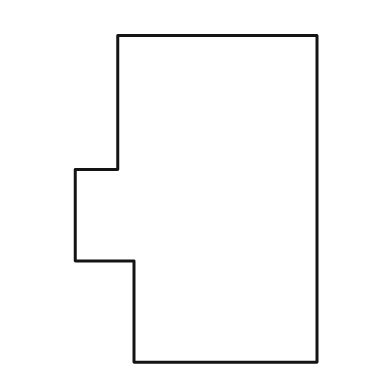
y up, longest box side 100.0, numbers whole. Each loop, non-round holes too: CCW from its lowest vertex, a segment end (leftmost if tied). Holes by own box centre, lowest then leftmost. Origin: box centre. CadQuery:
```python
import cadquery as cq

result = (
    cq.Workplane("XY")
    .moveTo(-19.0, -50.0)
    .lineTo(37.0, -50.0)
    .lineTo(37.0, 50.0)
    .lineTo(-24.0, 50.0)
    .lineTo(-24.0, 9.0)
    .lineTo(-37.0, 9.0)
    .lineTo(-37.0, -19.0)
    .lineTo(-19.0, -19.0)
    .close()
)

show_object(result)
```